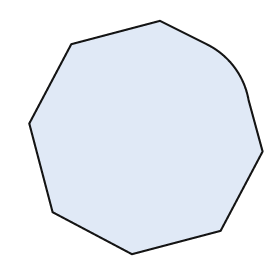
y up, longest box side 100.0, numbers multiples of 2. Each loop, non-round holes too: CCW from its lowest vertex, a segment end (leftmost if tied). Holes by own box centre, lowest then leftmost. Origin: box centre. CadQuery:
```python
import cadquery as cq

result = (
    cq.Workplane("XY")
    .moveTo(-6.0, -50.0)
    .lineTo(32.0, -40.0)
    .lineTo(50.0, -6.0)
    .lineTo(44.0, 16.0)
    .threePointArc((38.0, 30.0), (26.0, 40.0))
    .lineTo(6.0, 50.0)
    .lineTo(-32.0, 40.0)
    .lineTo(-50.0, 6.0)
    .lineTo(-40.0, -32.0)
    .close()
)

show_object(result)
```